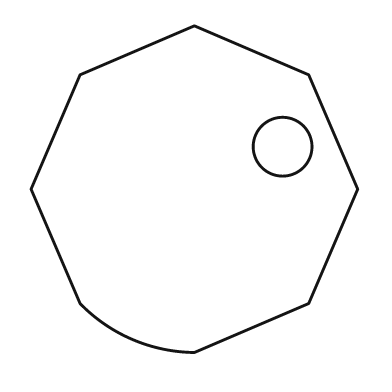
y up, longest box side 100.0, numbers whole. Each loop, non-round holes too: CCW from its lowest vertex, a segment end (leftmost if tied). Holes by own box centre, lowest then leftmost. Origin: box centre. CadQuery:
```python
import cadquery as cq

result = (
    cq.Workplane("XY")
    .moveTo(0.0, -50.0)
    .lineTo(35.0, -35.0)
    .lineTo(50.0, 0.0)
    .lineTo(35.0, 35.0)
    .lineTo(0.0, 50.0)
    .lineTo(-35.0, 35.0)
    .lineTo(-50.0, 0.0)
    .lineTo(-35.0, -35.0)
    .threePointArc((-19.0, -46.0), (0.0, -50.0))
    .close()
    .moveTo(27.0, 13.0)
    .circle(9.0)
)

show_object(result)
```